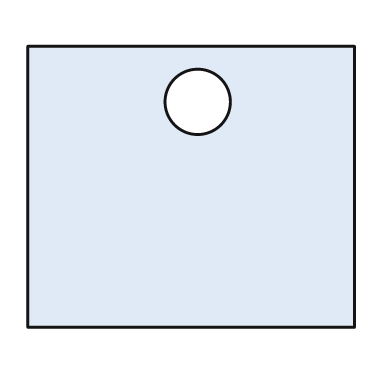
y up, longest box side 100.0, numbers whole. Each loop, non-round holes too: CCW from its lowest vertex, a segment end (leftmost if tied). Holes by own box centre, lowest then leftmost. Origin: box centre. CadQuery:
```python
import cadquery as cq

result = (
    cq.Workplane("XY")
    .moveTo(-50.0, -43.0)
    .lineTo(50.0, -43.0)
    .lineTo(50.0, 43.0)
    .lineTo(-50.0, 43.0)
    .close()
    .moveTo(2.0, 26.0)
    .circle(10.0)
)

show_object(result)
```